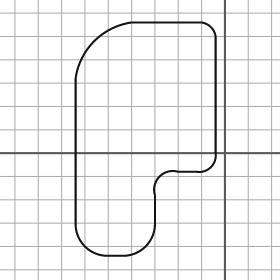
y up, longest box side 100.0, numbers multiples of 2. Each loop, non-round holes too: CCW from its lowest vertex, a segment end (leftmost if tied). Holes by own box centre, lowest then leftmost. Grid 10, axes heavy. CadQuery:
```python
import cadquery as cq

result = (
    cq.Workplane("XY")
    .moveTo(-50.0, -44.0)
    .lineTo(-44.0, -44.0)
    .threePointArc((-34.0, -40.0), (-30.0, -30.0))
    .lineTo(-30.0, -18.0)
    .threePointArc((-28.0, -10.0), (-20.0, -8.0))
    .lineTo(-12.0, -8.0)
    .threePointArc((-6.0, -6.0), (-4.0, 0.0))
    .lineTo(-4.0, 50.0)
    .threePointArc((-6.0, 54.0), (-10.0, 56.0))
    .lineTo(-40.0, 56.0)
    .threePointArc((-56.0, 48.0), (-64.0, 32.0))
    .lineTo(-64.0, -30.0)
    .threePointArc((-60.0, -40.0), (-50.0, -44.0))
    .close()
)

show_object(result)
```